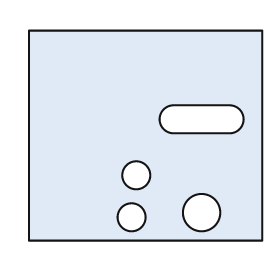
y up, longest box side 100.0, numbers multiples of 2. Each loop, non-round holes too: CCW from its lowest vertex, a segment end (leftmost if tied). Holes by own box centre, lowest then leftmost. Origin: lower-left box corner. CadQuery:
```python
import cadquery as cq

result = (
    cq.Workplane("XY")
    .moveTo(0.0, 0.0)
    .lineTo(100.0, 0.0)
    .lineTo(100.0, 90.0)
    .lineTo(0.0, 90.0)
    .close()
    .moveTo(44.0, 10.0)
    .circle(6.0)
    .moveTo(74.0, 12.0)
    .circle(8.0)
    .moveTo(46.0, 28.0)
    .circle(6.0)
    .moveTo(62.0, 46.0)
    .lineTo(86.0, 46.0)
    .threePointArc((92.0, 52.0), (86.0, 58.0))
    .lineTo(62.0, 58.0)
    .threePointArc((56.0, 52.0), (62.0, 46.0))
    .close()
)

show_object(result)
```